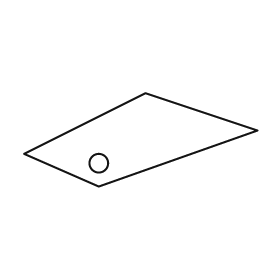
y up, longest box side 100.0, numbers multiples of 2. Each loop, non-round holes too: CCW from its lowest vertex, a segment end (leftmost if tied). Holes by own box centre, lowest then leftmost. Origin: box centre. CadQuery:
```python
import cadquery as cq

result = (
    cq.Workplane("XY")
    .moveTo(-18.0, -20.0)
    .lineTo(50.0, 4.0)
    .lineTo(2.0, 20.0)
    .lineTo(-50.0, -6.0)
    .close()
    .moveTo(-18.0, -10.0)
    .circle(4.0)
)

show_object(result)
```